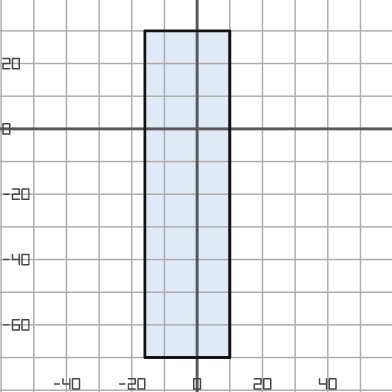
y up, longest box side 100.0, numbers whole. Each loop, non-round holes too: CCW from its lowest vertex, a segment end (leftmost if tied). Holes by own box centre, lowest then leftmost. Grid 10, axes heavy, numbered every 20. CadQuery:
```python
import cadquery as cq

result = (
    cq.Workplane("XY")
    .moveTo(-16.0, -70.0)
    .lineTo(10.0, -70.0)
    .lineTo(10.0, 30.0)
    .lineTo(-16.0, 30.0)
    .close()
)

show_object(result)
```